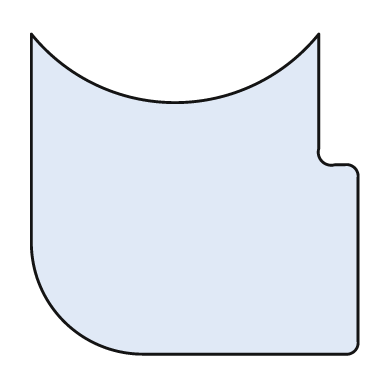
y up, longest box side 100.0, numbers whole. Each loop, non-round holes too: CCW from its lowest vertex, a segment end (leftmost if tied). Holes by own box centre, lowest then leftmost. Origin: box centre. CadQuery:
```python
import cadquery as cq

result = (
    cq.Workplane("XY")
    .moveTo(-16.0, -49.0)
    .lineTo(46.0, -49.0)
    .threePointArc((49.0, -48.0), (50.0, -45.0))
    .lineTo(50.0, 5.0)
    .threePointArc((49.0, 8.0), (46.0, 9.0))
    .lineTo(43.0, 9.0)
    .threePointArc((39.0, 10.0), (38.0, 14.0))
    .lineTo(38.0, 49.0)
    .threePointArc((-6.0, 28.0), (-50.0, 49.0))
    .lineTo(-50.0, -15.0)
    .threePointArc((-40.0, -39.0), (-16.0, -49.0))
    .close()
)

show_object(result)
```